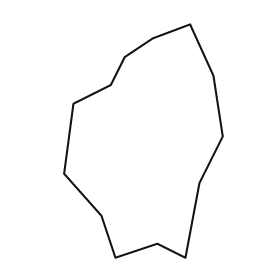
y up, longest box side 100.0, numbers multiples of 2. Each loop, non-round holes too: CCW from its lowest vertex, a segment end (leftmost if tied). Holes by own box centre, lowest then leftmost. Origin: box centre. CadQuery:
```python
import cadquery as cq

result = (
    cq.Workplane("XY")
    .moveTo(-12.0, -50.0)
    .lineTo(6.0, -44.0)
    .lineTo(18.0, -50.0)
    .lineTo(24.0, -18.0)
    .lineTo(34.0, 2.0)
    .lineTo(30.0, 28.0)
    .lineTo(20.0, 50.0)
    .lineTo(4.0, 44.0)
    .lineTo(-8.0, 36.0)
    .lineTo(-14.0, 24.0)
    .lineTo(-30.0, 16.0)
    .lineTo(-34.0, -14.0)
    .lineTo(-18.0, -32.0)
    .close()
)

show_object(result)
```